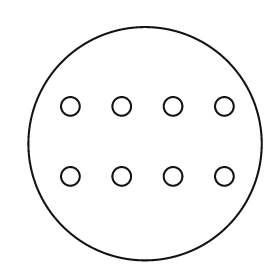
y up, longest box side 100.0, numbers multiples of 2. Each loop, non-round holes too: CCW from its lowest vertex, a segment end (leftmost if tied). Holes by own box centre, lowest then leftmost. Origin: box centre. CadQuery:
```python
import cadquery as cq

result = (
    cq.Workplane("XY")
    .moveTo(0.0, 0.0)
    .circle(50.0)
    .moveTo(-32.0, -14.0)
    .circle(4.0)
    .moveTo(-10.0, -14.0)
    .circle(4.0)
    .moveTo(12.0, -14.0)
    .circle(4.0)
    .moveTo(34.0, -14.0)
    .circle(4.0)
    .moveTo(-32.0, 16.0)
    .circle(4.0)
    .moveTo(-10.0, 16.0)
    .circle(4.0)
    .moveTo(12.0, 16.0)
    .circle(4.0)
    .moveTo(34.0, 16.0)
    .circle(4.0)
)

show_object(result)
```